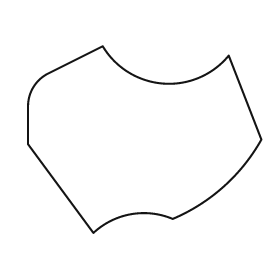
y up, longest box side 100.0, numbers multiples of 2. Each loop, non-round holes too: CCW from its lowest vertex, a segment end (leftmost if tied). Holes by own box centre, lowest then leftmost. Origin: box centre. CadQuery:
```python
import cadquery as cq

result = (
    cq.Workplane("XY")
    .moveTo(-22.0, -40.0)
    .threePointArc((-6.0, -32.0), (12.0, -34.0))
    .threePointArc((34.0, -20.0), (50.0, 0.0))
    .lineTo(36.0, 36.0)
    .threePointArc((8.0, 24.0), (-18.0, 40.0))
    .lineTo(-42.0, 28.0)
    .threePointArc((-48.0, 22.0), (-50.0, 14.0))
    .lineTo(-50.0, -2.0)
    .close()
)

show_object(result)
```